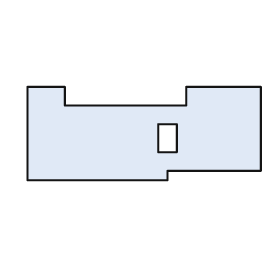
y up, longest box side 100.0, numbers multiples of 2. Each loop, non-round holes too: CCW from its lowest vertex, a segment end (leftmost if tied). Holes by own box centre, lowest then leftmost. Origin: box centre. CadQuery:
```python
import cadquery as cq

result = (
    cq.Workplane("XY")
    .moveTo(-50.0, -20.0)
    .lineTo(10.0, -20.0)
    .lineTo(10.0, -16.0)
    .lineTo(50.0, -16.0)
    .lineTo(50.0, 20.0)
    .lineTo(18.0, 20.0)
    .lineTo(18.0, 12.0)
    .lineTo(-34.0, 12.0)
    .lineTo(-34.0, 20.0)
    .lineTo(-50.0, 20.0)
    .close()
    .moveTo(6.0, -8.0)
    .lineTo(14.0, -8.0)
    .lineTo(14.0, 4.0)
    .lineTo(6.0, 4.0)
    .close()
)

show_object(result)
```